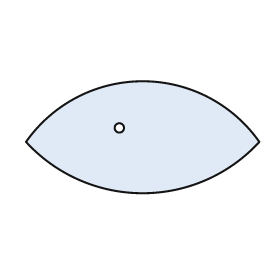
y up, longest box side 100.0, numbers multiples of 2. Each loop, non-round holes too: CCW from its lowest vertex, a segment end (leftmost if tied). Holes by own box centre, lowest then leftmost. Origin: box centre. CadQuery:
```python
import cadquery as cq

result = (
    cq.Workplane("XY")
    .moveTo(-50.0, -2.0)
    .threePointArc((0.0, -24.0), (50.0, -2.0))
    .threePointArc((0.0, 24.0), (-50.0, -2.0))
    .close()
    .moveTo(-10.0, 4.0)
    .circle(2.0)
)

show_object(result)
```